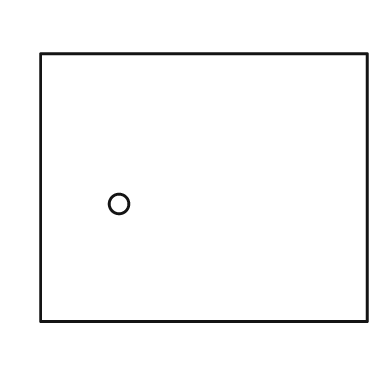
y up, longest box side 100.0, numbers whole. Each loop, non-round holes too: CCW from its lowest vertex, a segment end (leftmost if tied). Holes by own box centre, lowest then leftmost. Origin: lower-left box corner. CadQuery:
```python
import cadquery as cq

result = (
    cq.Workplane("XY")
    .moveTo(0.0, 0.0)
    .lineTo(100.0, 0.0)
    .lineTo(100.0, 82.0)
    .lineTo(0.0, 82.0)
    .close()
    .moveTo(24.0, 36.0)
    .circle(3.0)
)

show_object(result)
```